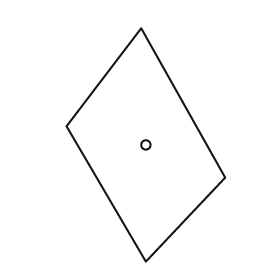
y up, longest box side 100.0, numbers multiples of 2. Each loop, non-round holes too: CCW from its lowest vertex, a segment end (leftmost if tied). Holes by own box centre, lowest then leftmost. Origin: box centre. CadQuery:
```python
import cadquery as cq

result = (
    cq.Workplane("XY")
    .moveTo(0.0, -50.0)
    .lineTo(34.0, -14.0)
    .lineTo(-2.0, 50.0)
    .lineTo(-34.0, 8.0)
    .close()
    .moveTo(0.0, 0.0)
    .circle(2.0)
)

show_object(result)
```